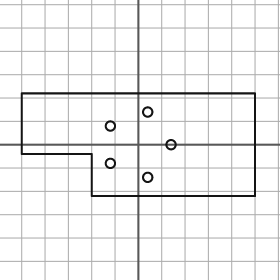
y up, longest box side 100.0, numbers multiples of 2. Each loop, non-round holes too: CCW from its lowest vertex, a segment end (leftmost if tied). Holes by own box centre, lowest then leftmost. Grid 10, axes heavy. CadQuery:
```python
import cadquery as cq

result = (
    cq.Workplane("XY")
    .moveTo(-20.0, -22.0)
    .lineTo(50.0, -22.0)
    .lineTo(50.0, 22.0)
    .lineTo(-50.0, 22.0)
    .lineTo(-50.0, -4.0)
    .lineTo(-20.0, -4.0)
    .close()
    .moveTo(4.0, -14.0)
    .circle(2.0)
    .moveTo(-12.0, -8.0)
    .circle(2.0)
    .moveTo(14.0, 0.0)
    .circle(2.0)
    .moveTo(-12.0, 8.0)
    .circle(2.0)
    .moveTo(4.0, 14.0)
    .circle(2.0)
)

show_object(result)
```